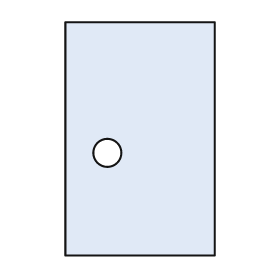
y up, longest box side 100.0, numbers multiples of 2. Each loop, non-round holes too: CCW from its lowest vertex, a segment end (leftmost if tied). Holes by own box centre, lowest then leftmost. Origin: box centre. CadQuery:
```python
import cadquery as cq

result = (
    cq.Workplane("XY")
    .moveTo(-32.0, -50.0)
    .lineTo(32.0, -50.0)
    .lineTo(32.0, 50.0)
    .lineTo(-32.0, 50.0)
    .close()
    .moveTo(-14.0, -6.0)
    .circle(6.0)
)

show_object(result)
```